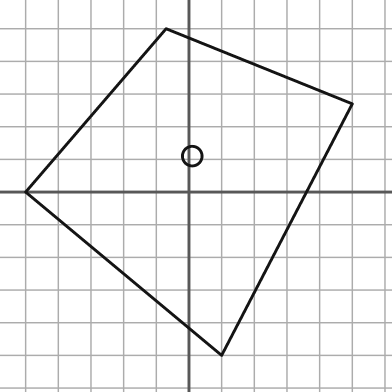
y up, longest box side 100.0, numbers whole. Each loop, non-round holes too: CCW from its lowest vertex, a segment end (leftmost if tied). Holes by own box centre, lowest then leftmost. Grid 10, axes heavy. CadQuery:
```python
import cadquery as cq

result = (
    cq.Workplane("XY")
    .moveTo(10.0, -50.0)
    .lineTo(50.0, 27.0)
    .lineTo(-7.0, 50.0)
    .lineTo(-50.0, 0.0)
    .close()
    .moveTo(1.0, 11.0)
    .circle(3.0)
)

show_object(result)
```